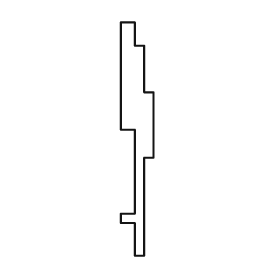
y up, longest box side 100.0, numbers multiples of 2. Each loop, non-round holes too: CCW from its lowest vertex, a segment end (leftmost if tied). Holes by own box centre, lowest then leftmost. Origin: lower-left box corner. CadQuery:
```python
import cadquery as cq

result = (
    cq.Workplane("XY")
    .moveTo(6.0, 0.0)
    .lineTo(10.0, 0.0)
    .lineTo(10.0, 42.0)
    .lineTo(14.0, 42.0)
    .lineTo(14.0, 70.0)
    .lineTo(10.0, 70.0)
    .lineTo(10.0, 90.0)
    .lineTo(6.0, 90.0)
    .lineTo(6.0, 100.0)
    .lineTo(0.0, 100.0)
    .lineTo(0.0, 54.0)
    .lineTo(6.0, 54.0)
    .lineTo(6.0, 18.0)
    .lineTo(0.0, 18.0)
    .lineTo(0.0, 14.0)
    .lineTo(6.0, 14.0)
    .close()
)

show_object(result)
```